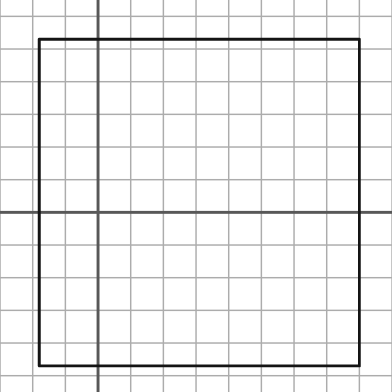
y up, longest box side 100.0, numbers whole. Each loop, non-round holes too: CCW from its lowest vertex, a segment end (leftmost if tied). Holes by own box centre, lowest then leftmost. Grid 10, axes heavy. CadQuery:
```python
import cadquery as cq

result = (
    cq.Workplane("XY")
    .moveTo(-18.0, -47.0)
    .lineTo(80.0, -47.0)
    .lineTo(80.0, 53.0)
    .lineTo(-18.0, 53.0)
    .close()
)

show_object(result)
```